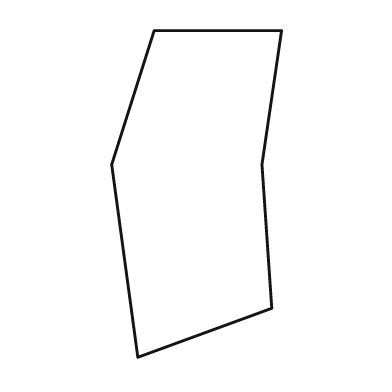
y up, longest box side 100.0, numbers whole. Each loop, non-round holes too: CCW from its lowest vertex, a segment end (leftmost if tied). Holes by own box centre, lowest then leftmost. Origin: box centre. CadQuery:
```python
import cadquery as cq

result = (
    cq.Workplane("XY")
    .moveTo(-18.0, -50.0)
    .lineTo(23.0, -35.0)
    .lineTo(20.0, 9.0)
    .lineTo(26.0, 50.0)
    .lineTo(-13.0, 50.0)
    .lineTo(-26.0, 9.0)
    .close()
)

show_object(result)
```